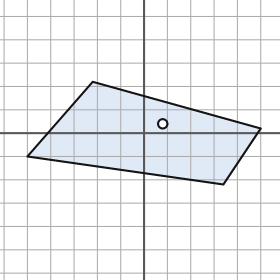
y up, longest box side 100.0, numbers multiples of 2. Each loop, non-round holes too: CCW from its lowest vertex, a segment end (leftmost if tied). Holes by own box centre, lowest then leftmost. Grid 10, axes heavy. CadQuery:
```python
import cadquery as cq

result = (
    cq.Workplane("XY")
    .moveTo(34.0, -22.0)
    .lineTo(50.0, 2.0)
    .lineTo(-22.0, 22.0)
    .lineTo(-50.0, -10.0)
    .close()
    .moveTo(8.0, 4.0)
    .circle(2.0)
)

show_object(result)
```